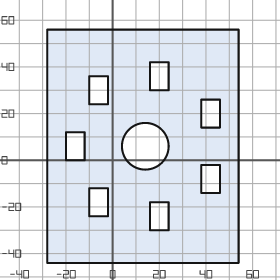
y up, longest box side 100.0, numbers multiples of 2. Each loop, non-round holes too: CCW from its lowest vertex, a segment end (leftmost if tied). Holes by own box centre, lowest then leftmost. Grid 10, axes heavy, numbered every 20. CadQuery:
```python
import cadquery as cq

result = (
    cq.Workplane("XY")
    .moveTo(-28.0, -44.0)
    .lineTo(54.0, -44.0)
    .lineTo(54.0, 56.0)
    .lineTo(-28.0, 56.0)
    .close()
    .moveTo(16.0, -30.0)
    .lineTo(24.0, -30.0)
    .lineTo(24.0, -18.0)
    .lineTo(16.0, -18.0)
    .close()
    .moveTo(-10.0, -24.0)
    .lineTo(-2.0, -24.0)
    .lineTo(-2.0, -12.0)
    .lineTo(-10.0, -12.0)
    .close()
    .moveTo(38.0, -14.0)
    .lineTo(46.0, -14.0)
    .lineTo(46.0, -2.0)
    .lineTo(38.0, -2.0)
    .close()
    .moveTo(-20.0, 0.0)
    .lineTo(-12.0, 0.0)
    .lineTo(-12.0, 12.0)
    .lineTo(-20.0, 12.0)
    .close()
    .moveTo(14.0, 6.0)
    .circle(10.0)
    .moveTo(38.0, 14.0)
    .lineTo(46.0, 14.0)
    .lineTo(46.0, 26.0)
    .lineTo(38.0, 26.0)
    .close()
    .moveTo(-10.0, 24.0)
    .lineTo(-2.0, 24.0)
    .lineTo(-2.0, 36.0)
    .lineTo(-10.0, 36.0)
    .close()
    .moveTo(16.0, 30.0)
    .lineTo(24.0, 30.0)
    .lineTo(24.0, 42.0)
    .lineTo(16.0, 42.0)
    .close()
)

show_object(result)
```